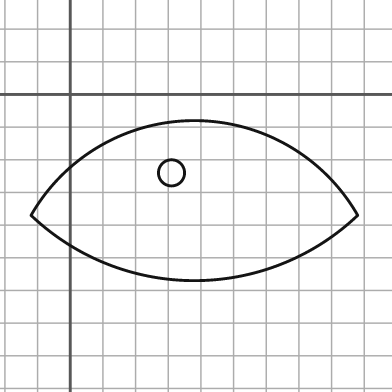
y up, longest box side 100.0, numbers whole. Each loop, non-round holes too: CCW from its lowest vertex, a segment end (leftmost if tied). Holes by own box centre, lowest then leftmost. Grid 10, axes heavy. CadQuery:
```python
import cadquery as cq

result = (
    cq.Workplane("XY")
    .moveTo(-12.0, -37.0)
    .threePointArc((38.0, -57.0), (88.0, -37.0))
    .threePointArc((38.0, -8.0), (-12.0, -37.0))
    .close()
    .moveTo(31.0, -24.0)
    .circle(4.0)
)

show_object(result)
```